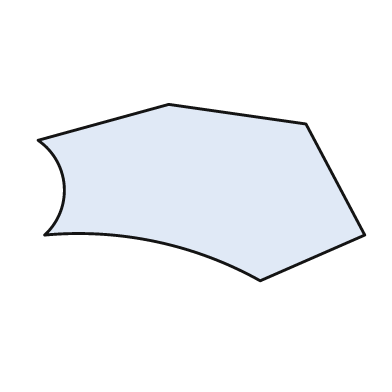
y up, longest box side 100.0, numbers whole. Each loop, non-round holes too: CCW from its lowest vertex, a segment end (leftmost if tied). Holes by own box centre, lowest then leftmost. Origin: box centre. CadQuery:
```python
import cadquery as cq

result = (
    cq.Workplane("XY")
    .moveTo(18.0, -27.0)
    .lineTo(50.0, -13.0)
    .lineTo(32.0, 21.0)
    .lineTo(-10.0, 27.0)
    .lineTo(-50.0, 16.0)
    .threePointArc((-42.0, 2.0), (-48.0, -13.0))
    .threePointArc((-14.0, -15.0), (18.0, -27.0))
    .close()
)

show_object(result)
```